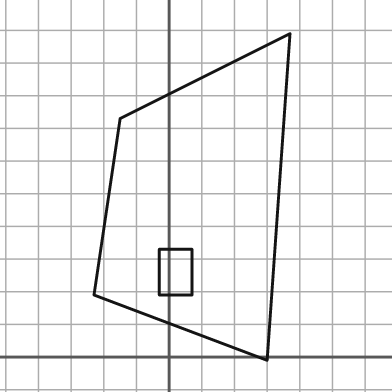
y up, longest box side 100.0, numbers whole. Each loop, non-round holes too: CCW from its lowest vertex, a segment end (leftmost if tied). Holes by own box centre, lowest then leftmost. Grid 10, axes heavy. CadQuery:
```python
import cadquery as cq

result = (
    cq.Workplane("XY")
    .moveTo(30.0, -1.0)
    .lineTo(37.0, 99.0)
    .lineTo(-15.0, 73.0)
    .lineTo(-23.0, 19.0)
    .close()
    .moveTo(-3.0, 19.0)
    .lineTo(7.0, 19.0)
    .lineTo(7.0, 33.0)
    .lineTo(-3.0, 33.0)
    .close()
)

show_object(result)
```